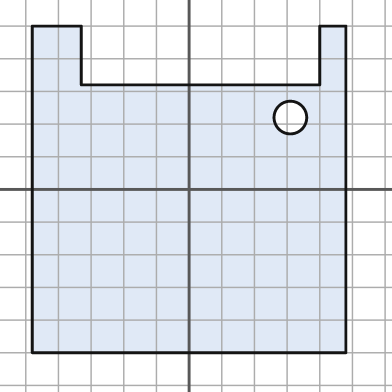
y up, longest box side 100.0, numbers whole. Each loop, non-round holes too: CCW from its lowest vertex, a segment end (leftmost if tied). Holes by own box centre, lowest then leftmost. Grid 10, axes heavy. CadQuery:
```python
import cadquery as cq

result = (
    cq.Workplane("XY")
    .moveTo(-48.0, -50.0)
    .lineTo(48.0, -50.0)
    .lineTo(48.0, 50.0)
    .lineTo(40.0, 50.0)
    .lineTo(40.0, 32.0)
    .lineTo(-33.0, 32.0)
    .lineTo(-33.0, 50.0)
    .lineTo(-48.0, 50.0)
    .close()
    .moveTo(31.0, 22.0)
    .circle(5.0)
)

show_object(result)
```